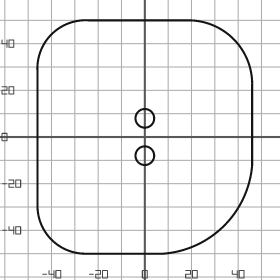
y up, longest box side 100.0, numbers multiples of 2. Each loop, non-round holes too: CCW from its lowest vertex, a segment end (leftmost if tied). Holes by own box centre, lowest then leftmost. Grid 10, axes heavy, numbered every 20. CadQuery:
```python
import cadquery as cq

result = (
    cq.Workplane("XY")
    .moveTo(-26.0, -50.0)
    .lineTo(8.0, -50.0)
    .threePointArc((34.0, -38.0), (46.0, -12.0))
    .lineTo(46.0, 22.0)
    .threePointArc((38.0, 42.0), (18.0, 50.0))
    .lineTo(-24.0, 50.0)
    .threePointArc((-40.0, 44.0), (-46.0, 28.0))
    .lineTo(-46.0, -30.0)
    .threePointArc((-40.0, -44.0), (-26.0, -50.0))
    .close()
    .moveTo(0.0, -8.0)
    .circle(4.0)
    .moveTo(0.0, 8.0)
    .circle(4.0)
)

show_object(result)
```